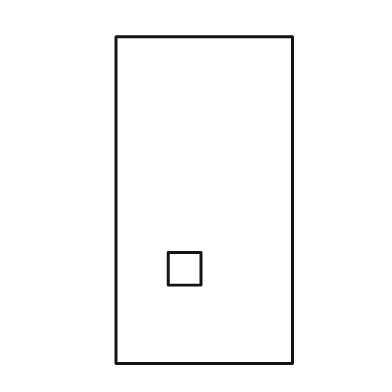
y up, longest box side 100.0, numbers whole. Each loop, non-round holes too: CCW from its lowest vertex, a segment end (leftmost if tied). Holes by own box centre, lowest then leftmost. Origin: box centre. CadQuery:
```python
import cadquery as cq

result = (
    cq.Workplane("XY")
    .moveTo(-27.0, -50.0)
    .lineTo(27.0, -50.0)
    .lineTo(27.0, 50.0)
    .lineTo(-27.0, 50.0)
    .close()
    .moveTo(-11.0, -26.0)
    .lineTo(-1.0, -26.0)
    .lineTo(-1.0, -16.0)
    .lineTo(-11.0, -16.0)
    .close()
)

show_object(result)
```